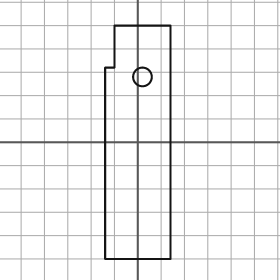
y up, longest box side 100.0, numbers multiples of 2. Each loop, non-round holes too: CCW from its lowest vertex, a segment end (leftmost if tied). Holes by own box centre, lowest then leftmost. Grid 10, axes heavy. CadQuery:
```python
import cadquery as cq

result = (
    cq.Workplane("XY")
    .moveTo(-14.0, -50.0)
    .lineTo(14.0, -50.0)
    .lineTo(14.0, 50.0)
    .lineTo(-10.0, 50.0)
    .lineTo(-10.0, 32.0)
    .lineTo(-14.0, 32.0)
    .close()
    .moveTo(2.0, 28.0)
    .circle(4.0)
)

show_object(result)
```